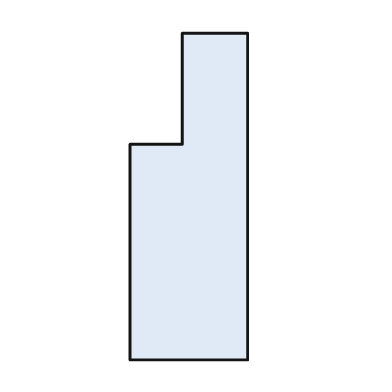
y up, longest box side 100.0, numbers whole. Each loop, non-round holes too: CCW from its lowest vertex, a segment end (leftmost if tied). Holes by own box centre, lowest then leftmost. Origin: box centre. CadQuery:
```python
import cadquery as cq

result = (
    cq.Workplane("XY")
    .moveTo(-18.0, -50.0)
    .lineTo(18.0, -50.0)
    .lineTo(18.0, 50.0)
    .lineTo(-2.0, 50.0)
    .lineTo(-2.0, 16.0)
    .lineTo(-18.0, 16.0)
    .close()
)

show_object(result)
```